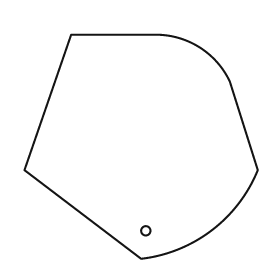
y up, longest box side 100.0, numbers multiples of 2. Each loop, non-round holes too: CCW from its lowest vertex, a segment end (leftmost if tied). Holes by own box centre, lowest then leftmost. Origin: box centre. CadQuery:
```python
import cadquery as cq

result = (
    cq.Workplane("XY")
    .moveTo(0.0, -48.0)
    .threePointArc((30.0, -36.0), (50.0, -10.0))
    .lineTo(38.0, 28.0)
    .threePointArc((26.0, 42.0), (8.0, 48.0))
    .lineTo(-30.0, 48.0)
    .lineTo(-50.0, -10.0)
    .close()
    .moveTo(2.0, -36.0)
    .circle(2.0)
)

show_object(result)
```